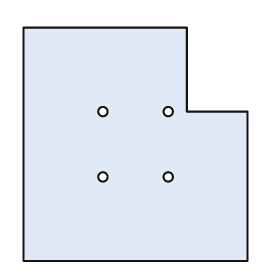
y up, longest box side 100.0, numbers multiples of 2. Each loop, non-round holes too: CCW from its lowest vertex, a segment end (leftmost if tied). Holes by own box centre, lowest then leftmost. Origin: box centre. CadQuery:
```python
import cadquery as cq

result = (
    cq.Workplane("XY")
    .moveTo(-48.0, -50.0)
    .lineTo(48.0, -50.0)
    .lineTo(48.0, 14.0)
    .lineTo(22.0, 14.0)
    .lineTo(22.0, 50.0)
    .lineTo(-48.0, 50.0)
    .close()
    .moveTo(-14.0, -14.0)
    .circle(2.0)
    .moveTo(14.0, -14.0)
    .circle(2.0)
    .moveTo(-14.0, 14.0)
    .circle(2.0)
    .moveTo(14.0, 14.0)
    .circle(2.0)
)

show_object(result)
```